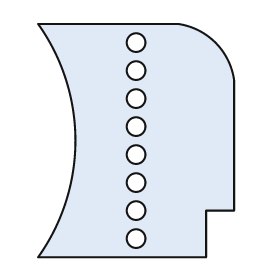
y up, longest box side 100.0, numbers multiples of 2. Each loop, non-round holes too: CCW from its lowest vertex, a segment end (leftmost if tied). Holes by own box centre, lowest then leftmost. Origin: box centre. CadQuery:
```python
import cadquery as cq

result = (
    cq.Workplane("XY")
    .moveTo(-42.0, -50.0)
    .lineTo(30.0, -50.0)
    .lineTo(30.0, -30.0)
    .lineTo(42.0, -30.0)
    .lineTo(42.0, 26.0)
    .threePointArc((34.0, 42.0), (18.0, 50.0))
    .lineTo(-42.0, 50.0)
    .threePointArc((-26.0, 0.0), (-42.0, -50.0))
    .close()
    .moveTo(0.0, -42.0)
    .circle(4.0)
    .moveTo(0.0, -30.0)
    .circle(4.0)
    .moveTo(0.0, -18.0)
    .circle(4.0)
    .moveTo(0.0, -6.0)
    .circle(4.0)
    .moveTo(0.0, 6.0)
    .circle(4.0)
    .moveTo(0.0, 18.0)
    .circle(4.0)
    .moveTo(0.0, 30.0)
    .circle(4.0)
    .moveTo(0.0, 42.0)
    .circle(4.0)
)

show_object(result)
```